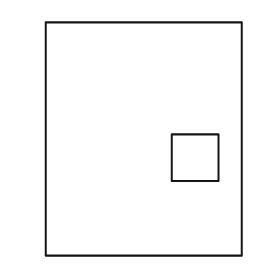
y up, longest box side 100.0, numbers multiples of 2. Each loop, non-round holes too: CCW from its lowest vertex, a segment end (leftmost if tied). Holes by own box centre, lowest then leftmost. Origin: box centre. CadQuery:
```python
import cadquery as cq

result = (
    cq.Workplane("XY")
    .moveTo(-42.0, -50.0)
    .lineTo(42.0, -50.0)
    .lineTo(42.0, 50.0)
    .lineTo(-42.0, 50.0)
    .close()
    .moveTo(12.0, -18.0)
    .lineTo(32.0, -18.0)
    .lineTo(32.0, 2.0)
    .lineTo(12.0, 2.0)
    .close()
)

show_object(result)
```